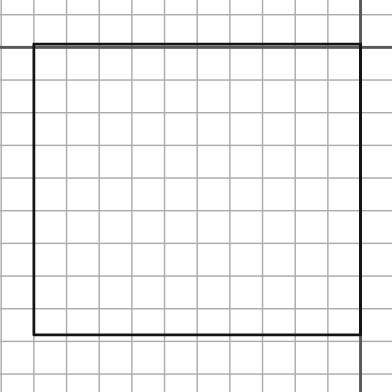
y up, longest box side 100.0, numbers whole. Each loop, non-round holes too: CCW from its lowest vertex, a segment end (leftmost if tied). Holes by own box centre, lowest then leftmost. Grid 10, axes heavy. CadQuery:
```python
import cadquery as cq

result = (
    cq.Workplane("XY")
    .moveTo(-100.0, -88.0)
    .lineTo(0.0, -88.0)
    .lineTo(0.0, 1.0)
    .lineTo(-100.0, 1.0)
    .close()
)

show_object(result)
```